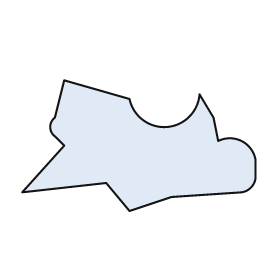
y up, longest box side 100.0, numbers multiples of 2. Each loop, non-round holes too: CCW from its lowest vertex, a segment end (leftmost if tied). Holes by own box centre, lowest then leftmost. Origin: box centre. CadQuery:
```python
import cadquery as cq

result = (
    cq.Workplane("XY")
    .moveTo(-4.0, -28.0)
    .lineTo(14.0, -22.0)
    .lineTo(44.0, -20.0)
    .threePointArc((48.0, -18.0), (50.0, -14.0))
    .lineTo(50.0, -6.0)
    .threePointArc((44.0, 2.0), (34.0, 2.0))
    .lineTo(32.0, 12.0)
    .lineTo(26.0, 22.0)
    .threePointArc((12.0, 8.0), (-4.0, 20.0))
    .lineTo(-32.0, 28.0)
    .lineTo(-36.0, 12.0)
    .threePointArc((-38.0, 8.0), (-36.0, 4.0))
    .lineTo(-32.0, 0.0)
    .lineTo(-50.0, -20.0)
    .lineTo(-14.0, -16.0)
    .close()
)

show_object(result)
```